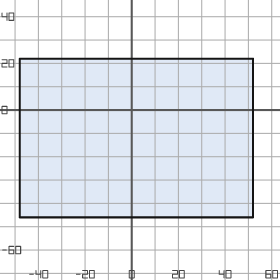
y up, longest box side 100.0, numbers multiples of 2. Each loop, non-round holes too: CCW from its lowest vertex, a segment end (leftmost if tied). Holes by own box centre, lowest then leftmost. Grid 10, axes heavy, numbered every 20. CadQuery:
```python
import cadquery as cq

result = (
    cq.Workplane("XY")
    .moveTo(-48.0, -46.0)
    .lineTo(52.0, -46.0)
    .lineTo(52.0, 22.0)
    .lineTo(-48.0, 22.0)
    .close()
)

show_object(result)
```